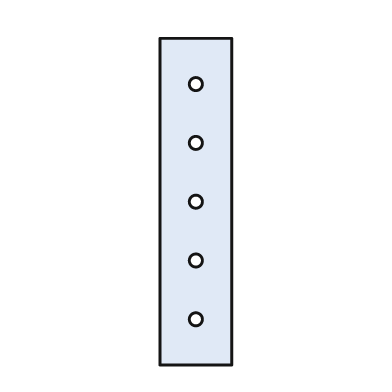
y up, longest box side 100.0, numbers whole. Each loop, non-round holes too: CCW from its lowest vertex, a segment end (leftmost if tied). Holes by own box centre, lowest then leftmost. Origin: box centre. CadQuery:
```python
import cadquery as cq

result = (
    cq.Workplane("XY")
    .moveTo(-11.0, -50.0)
    .lineTo(11.0, -50.0)
    .lineTo(11.0, 50.0)
    .lineTo(-11.0, 50.0)
    .close()
    .moveTo(0.0, -36.0)
    .circle(2.0)
    .moveTo(0.0, -18.0)
    .circle(2.0)
    .moveTo(0.0, 0.0)
    .circle(2.0)
    .moveTo(0.0, 18.0)
    .circle(2.0)
    .moveTo(0.0, 36.0)
    .circle(2.0)
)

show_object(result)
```